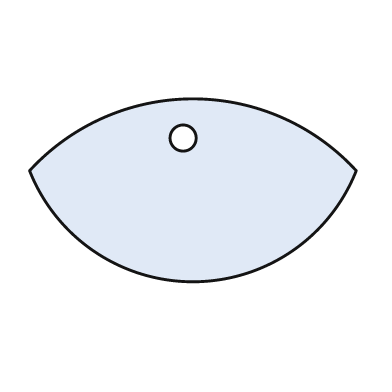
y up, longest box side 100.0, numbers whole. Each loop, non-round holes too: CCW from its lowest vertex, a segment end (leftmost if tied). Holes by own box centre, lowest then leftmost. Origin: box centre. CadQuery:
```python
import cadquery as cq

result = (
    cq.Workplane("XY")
    .moveTo(-50.0, 6.0)
    .threePointArc((0.0, -28.0), (50.0, 6.0))
    .threePointArc((0.0, 28.0), (-50.0, 6.0))
    .close()
    .moveTo(-3.0, 16.0)
    .circle(4.0)
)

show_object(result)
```